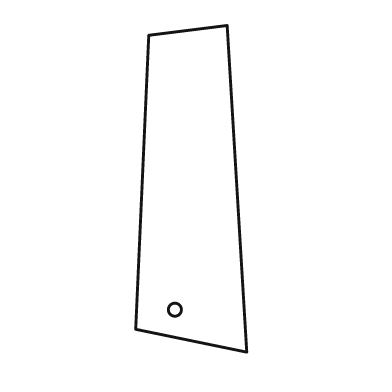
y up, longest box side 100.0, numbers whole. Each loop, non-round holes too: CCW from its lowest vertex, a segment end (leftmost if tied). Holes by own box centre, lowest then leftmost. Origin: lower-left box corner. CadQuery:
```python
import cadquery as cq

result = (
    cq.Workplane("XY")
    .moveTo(34.0, 0.0)
    .lineTo(28.0, 100.0)
    .lineTo(4.0, 97.0)
    .lineTo(0.0, 7.0)
    .close()
    .moveTo(12.0, 13.0)
    .circle(2.0)
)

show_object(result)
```